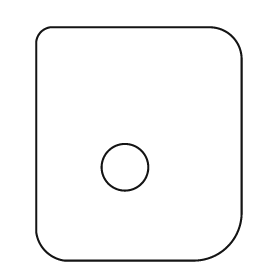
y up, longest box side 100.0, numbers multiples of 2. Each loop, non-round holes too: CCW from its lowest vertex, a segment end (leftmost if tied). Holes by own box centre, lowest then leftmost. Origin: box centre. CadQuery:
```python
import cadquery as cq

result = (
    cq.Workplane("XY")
    .moveTo(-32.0, -50.0)
    .lineTo(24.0, -50.0)
    .threePointArc((38.0, -44.0), (44.0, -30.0))
    .lineTo(44.0, 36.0)
    .threePointArc((40.0, 46.0), (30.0, 50.0))
    .lineTo(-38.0, 50.0)
    .threePointArc((-42.0, 48.0), (-44.0, 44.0))
    .lineTo(-44.0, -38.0)
    .threePointArc((-40.0, -46.0), (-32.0, -50.0))
    .close()
    .moveTo(-6.0, -10.0)
    .circle(10.0)
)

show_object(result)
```